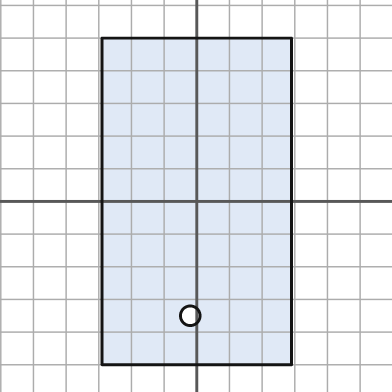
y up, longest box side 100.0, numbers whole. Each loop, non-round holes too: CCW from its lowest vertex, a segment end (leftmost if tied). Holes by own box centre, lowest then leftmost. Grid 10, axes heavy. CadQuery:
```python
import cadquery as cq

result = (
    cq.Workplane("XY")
    .moveTo(-29.0, -50.0)
    .lineTo(29.0, -50.0)
    .lineTo(29.0, 50.0)
    .lineTo(-29.0, 50.0)
    .close()
    .moveTo(-2.0, -35.0)
    .circle(3.0)
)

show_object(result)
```